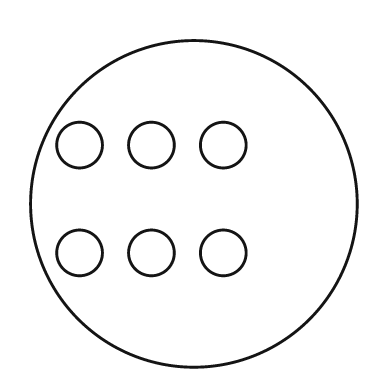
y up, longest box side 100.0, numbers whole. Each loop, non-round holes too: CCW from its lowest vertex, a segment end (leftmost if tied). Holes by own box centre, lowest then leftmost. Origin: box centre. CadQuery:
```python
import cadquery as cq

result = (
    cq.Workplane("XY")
    .moveTo(0.0, 0.0)
    .circle(50.0)
    .moveTo(-35.0, -15.0)
    .circle(7.0)
    .moveTo(-13.0, -15.0)
    .circle(7.0)
    .moveTo(9.0, -15.0)
    .circle(7.0)
    .moveTo(-35.0, 18.0)
    .circle(7.0)
    .moveTo(-13.0, 18.0)
    .circle(7.0)
    .moveTo(9.0, 18.0)
    .circle(7.0)
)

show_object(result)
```